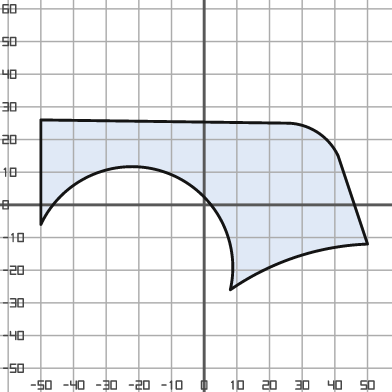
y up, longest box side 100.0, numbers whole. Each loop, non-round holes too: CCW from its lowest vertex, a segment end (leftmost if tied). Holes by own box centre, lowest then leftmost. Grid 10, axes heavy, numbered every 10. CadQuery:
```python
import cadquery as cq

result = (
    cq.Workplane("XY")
    .moveTo(8.0, -26.0)
    .threePointArc((28.0, -16.0), (50.0, -12.0))
    .lineTo(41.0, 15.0)
    .threePointArc((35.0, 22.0), (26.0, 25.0))
    .lineTo(-50.0, 26.0)
    .lineTo(-50.0, -6.0)
    .threePointArc((-12.0, 10.0), (8.0, -26.0))
    .close()
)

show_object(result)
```